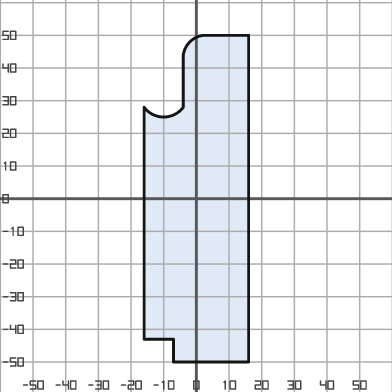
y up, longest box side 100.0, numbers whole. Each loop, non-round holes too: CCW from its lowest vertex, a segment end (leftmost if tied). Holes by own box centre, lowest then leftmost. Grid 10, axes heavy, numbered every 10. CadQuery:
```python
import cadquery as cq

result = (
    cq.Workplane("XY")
    .moveTo(-7.0, -50.0)
    .lineTo(16.0, -50.0)
    .lineTo(16.0, 50.0)
    .lineTo(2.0, 50.0)
    .threePointArc((-2.0, 48.0), (-4.0, 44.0))
    .lineTo(-4.0, 28.0)
    .threePointArc((-10.0, 25.0), (-16.0, 28.0))
    .lineTo(-16.0, -43.0)
    .lineTo(-7.0, -43.0)
    .close()
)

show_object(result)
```